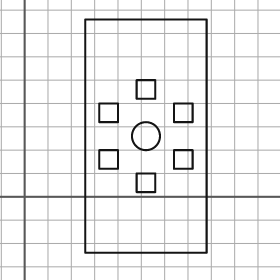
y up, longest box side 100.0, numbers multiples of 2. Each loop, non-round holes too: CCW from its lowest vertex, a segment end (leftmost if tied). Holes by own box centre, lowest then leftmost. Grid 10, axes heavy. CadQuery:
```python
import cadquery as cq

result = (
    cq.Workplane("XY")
    .moveTo(26.0, -24.0)
    .lineTo(78.0, -24.0)
    .lineTo(78.0, 76.0)
    .lineTo(26.0, 76.0)
    .close()
    .moveTo(48.0, 2.0)
    .lineTo(56.0, 2.0)
    .lineTo(56.0, 10.0)
    .lineTo(48.0, 10.0)
    .close()
    .moveTo(32.0, 12.0)
    .lineTo(40.0, 12.0)
    .lineTo(40.0, 20.0)
    .lineTo(32.0, 20.0)
    .close()
    .moveTo(64.0, 12.0)
    .lineTo(72.0, 12.0)
    .lineTo(72.0, 20.0)
    .lineTo(64.0, 20.0)
    .close()
    .moveTo(52.0, 26.0)
    .circle(6.0)
    .moveTo(32.0, 32.0)
    .lineTo(40.0, 32.0)
    .lineTo(40.0, 40.0)
    .lineTo(32.0, 40.0)
    .close()
    .moveTo(64.0, 32.0)
    .lineTo(72.0, 32.0)
    .lineTo(72.0, 40.0)
    .lineTo(64.0, 40.0)
    .close()
    .moveTo(48.0, 42.0)
    .lineTo(56.0, 42.0)
    .lineTo(56.0, 50.0)
    .lineTo(48.0, 50.0)
    .close()
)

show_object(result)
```